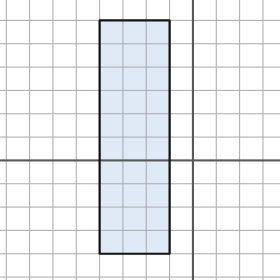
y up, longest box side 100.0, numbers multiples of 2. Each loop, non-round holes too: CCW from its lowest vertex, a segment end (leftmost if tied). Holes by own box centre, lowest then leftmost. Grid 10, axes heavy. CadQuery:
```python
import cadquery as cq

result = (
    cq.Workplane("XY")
    .moveTo(-40.0, -40.0)
    .lineTo(-10.0, -40.0)
    .lineTo(-10.0, 60.0)
    .lineTo(-40.0, 60.0)
    .close()
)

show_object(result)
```